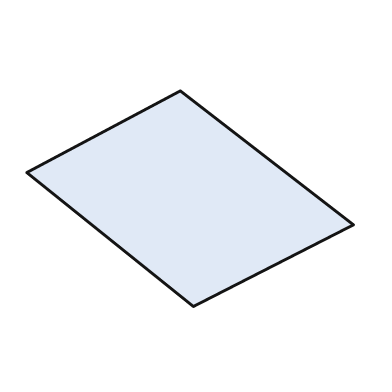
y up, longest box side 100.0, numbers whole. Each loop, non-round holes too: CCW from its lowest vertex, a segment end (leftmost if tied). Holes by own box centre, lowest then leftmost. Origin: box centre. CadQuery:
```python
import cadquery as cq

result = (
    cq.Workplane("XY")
    .moveTo(1.0, -33.0)
    .lineTo(50.0, -8.0)
    .lineTo(-3.0, 33.0)
    .lineTo(-50.0, 8.0)
    .close()
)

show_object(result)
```